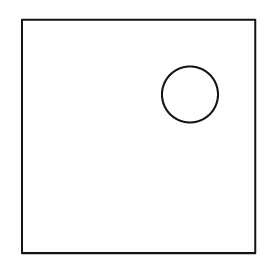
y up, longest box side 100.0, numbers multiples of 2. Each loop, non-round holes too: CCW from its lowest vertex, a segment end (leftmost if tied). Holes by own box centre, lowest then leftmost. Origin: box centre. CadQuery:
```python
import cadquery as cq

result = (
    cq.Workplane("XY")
    .moveTo(-50.0, -50.0)
    .lineTo(50.0, -50.0)
    .lineTo(50.0, 50.0)
    .lineTo(-50.0, 50.0)
    .close()
    .moveTo(22.0, 18.0)
    .circle(12.0)
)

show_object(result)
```